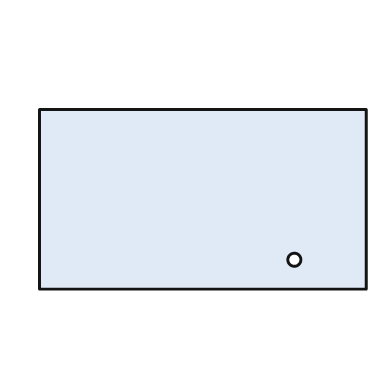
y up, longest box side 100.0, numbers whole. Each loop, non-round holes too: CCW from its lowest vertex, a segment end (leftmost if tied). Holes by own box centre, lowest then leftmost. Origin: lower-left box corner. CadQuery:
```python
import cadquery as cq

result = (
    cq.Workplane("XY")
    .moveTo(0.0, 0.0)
    .lineTo(100.0, 0.0)
    .lineTo(100.0, 55.0)
    .lineTo(0.0, 55.0)
    .close()
    .moveTo(78.0, 9.0)
    .circle(2.0)
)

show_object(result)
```